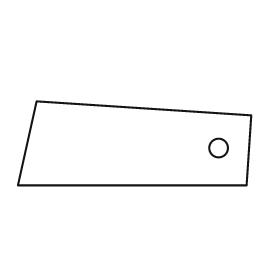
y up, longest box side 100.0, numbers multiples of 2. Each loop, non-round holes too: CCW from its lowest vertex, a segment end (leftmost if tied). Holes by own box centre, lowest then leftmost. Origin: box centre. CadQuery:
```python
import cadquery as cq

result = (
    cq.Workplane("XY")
    .moveTo(-50.0, -18.0)
    .lineTo(48.0, -18.0)
    .lineTo(50.0, 12.0)
    .lineTo(-42.0, 18.0)
    .close()
    .moveTo(36.0, -2.0)
    .circle(4.0)
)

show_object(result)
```